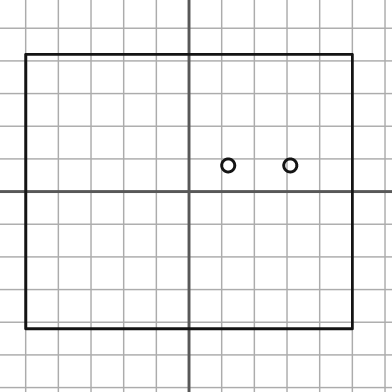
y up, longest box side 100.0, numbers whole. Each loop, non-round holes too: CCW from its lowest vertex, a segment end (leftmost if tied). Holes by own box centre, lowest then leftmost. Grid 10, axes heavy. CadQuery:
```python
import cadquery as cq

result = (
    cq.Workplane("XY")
    .moveTo(-50.0, -42.0)
    .lineTo(50.0, -42.0)
    .lineTo(50.0, 42.0)
    .lineTo(-50.0, 42.0)
    .close()
    .moveTo(12.0, 8.0)
    .circle(2.0)
    .moveTo(31.0, 8.0)
    .circle(2.0)
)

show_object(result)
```